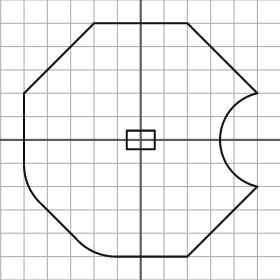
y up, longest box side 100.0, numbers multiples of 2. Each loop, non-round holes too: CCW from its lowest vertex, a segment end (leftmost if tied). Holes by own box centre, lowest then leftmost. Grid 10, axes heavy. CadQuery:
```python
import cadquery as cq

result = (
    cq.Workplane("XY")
    .moveTo(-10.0, -50.0)
    .lineTo(20.0, -50.0)
    .lineTo(50.0, -20.0)
    .threePointArc((34.0, 0.0), (50.0, 20.0))
    .lineTo(20.0, 50.0)
    .lineTo(-20.0, 50.0)
    .lineTo(-50.0, 20.0)
    .lineTo(-50.0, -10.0)
    .threePointArc((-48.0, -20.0), (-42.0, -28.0))
    .lineTo(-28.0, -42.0)
    .threePointArc((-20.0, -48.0), (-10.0, -50.0))
    .close()
    .moveTo(-6.0, -4.0)
    .lineTo(6.0, -4.0)
    .lineTo(6.0, 4.0)
    .lineTo(-6.0, 4.0)
    .close()
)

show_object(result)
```